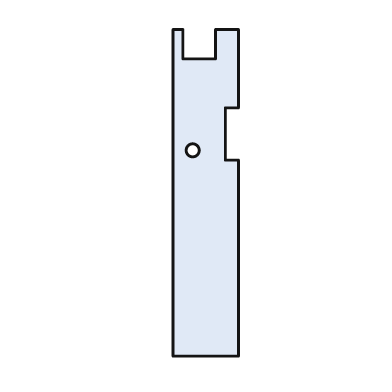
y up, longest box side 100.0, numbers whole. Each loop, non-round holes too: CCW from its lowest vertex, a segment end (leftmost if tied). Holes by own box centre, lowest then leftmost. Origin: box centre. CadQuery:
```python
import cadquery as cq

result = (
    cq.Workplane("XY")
    .moveTo(-10.0, -50.0)
    .lineTo(10.0, -50.0)
    .lineTo(10.0, 10.0)
    .lineTo(6.0, 10.0)
    .lineTo(6.0, 26.0)
    .lineTo(10.0, 26.0)
    .lineTo(10.0, 50.0)
    .lineTo(3.0, 50.0)
    .lineTo(3.0, 41.0)
    .lineTo(-7.0, 41.0)
    .lineTo(-7.0, 50.0)
    .lineTo(-10.0, 50.0)
    .close()
    .moveTo(-4.0, 13.0)
    .circle(2.0)
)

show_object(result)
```